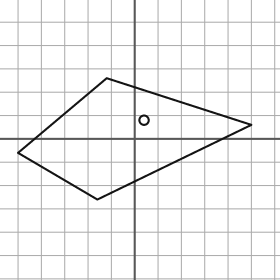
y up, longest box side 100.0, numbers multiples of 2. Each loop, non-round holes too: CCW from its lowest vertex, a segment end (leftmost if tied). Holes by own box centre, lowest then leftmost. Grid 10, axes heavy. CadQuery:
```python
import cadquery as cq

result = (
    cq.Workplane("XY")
    .moveTo(-16.0, -26.0)
    .lineTo(50.0, 6.0)
    .lineTo(-12.0, 26.0)
    .lineTo(-50.0, -6.0)
    .close()
    .moveTo(4.0, 8.0)
    .circle(2.0)
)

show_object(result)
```